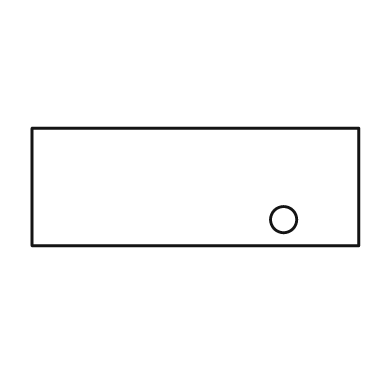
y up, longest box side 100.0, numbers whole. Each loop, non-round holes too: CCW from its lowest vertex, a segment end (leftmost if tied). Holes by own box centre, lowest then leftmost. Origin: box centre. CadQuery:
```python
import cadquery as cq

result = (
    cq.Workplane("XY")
    .moveTo(-50.0, -18.0)
    .lineTo(50.0, -18.0)
    .lineTo(50.0, 18.0)
    .lineTo(-50.0, 18.0)
    .close()
    .moveTo(27.0, -10.0)
    .circle(4.0)
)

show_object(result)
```